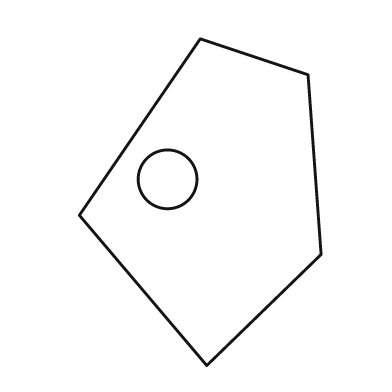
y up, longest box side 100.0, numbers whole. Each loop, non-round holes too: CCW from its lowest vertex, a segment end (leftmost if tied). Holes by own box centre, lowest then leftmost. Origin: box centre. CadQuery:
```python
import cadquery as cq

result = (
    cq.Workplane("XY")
    .moveTo(2.0, -50.0)
    .lineTo(37.0, -16.0)
    .lineTo(33.0, 39.0)
    .lineTo(0.0, 50.0)
    .lineTo(-37.0, -4.0)
    .close()
    .moveTo(-10.0, 7.0)
    .circle(9.0)
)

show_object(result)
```